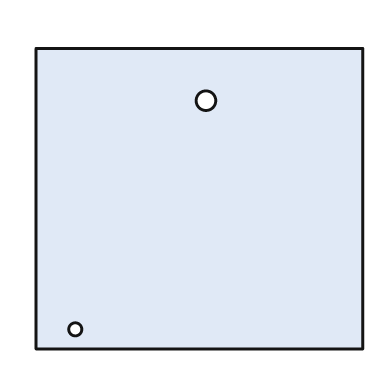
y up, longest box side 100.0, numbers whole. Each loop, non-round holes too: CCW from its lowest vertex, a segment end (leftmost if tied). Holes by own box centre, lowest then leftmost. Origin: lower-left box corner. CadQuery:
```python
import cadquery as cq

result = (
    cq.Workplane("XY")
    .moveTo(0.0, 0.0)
    .lineTo(100.0, 0.0)
    .lineTo(100.0, 92.0)
    .lineTo(0.0, 92.0)
    .close()
    .moveTo(12.0, 6.0)
    .circle(2.0)
    .moveTo(52.0, 76.0)
    .circle(3.0)
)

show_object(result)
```